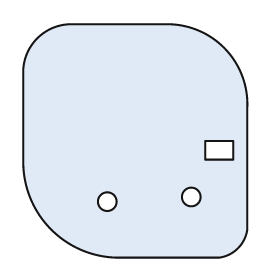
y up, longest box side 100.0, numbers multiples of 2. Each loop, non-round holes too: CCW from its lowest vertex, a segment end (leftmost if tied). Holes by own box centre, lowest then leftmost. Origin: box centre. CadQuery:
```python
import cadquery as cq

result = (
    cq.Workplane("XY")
    .moveTo(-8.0, -50.0)
    .lineTo(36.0, -50.0)
    .threePointArc((44.0, -46.0), (48.0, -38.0))
    .lineTo(48.0, 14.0)
    .threePointArc((38.0, 40.0), (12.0, 50.0))
    .lineTo(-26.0, 50.0)
    .threePointArc((-42.0, 44.0), (-48.0, 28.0))
    .lineTo(-48.0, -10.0)
    .threePointArc((-36.0, -38.0), (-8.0, -50.0))
    .close()
    .moveTo(-12.0, -26.0)
    .circle(4.0)
    .moveTo(24.0, -24.0)
    .circle(4.0)
    .moveTo(30.0, -8.0)
    .lineTo(42.0, -8.0)
    .lineTo(42.0, 0.0)
    .lineTo(30.0, 0.0)
    .close()
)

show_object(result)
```